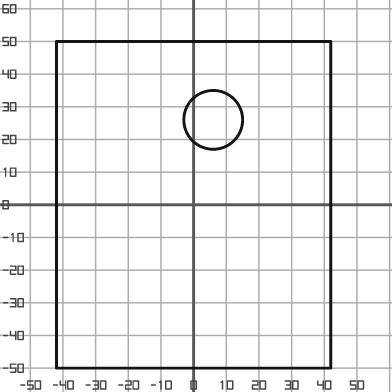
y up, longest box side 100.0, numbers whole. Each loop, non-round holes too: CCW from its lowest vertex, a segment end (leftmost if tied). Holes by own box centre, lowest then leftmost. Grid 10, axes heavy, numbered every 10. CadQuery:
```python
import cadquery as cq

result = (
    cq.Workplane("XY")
    .moveTo(-42.0, -50.0)
    .lineTo(42.0, -50.0)
    .lineTo(42.0, 50.0)
    .lineTo(-42.0, 50.0)
    .close()
    .moveTo(6.0, 26.0)
    .circle(9.0)
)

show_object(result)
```